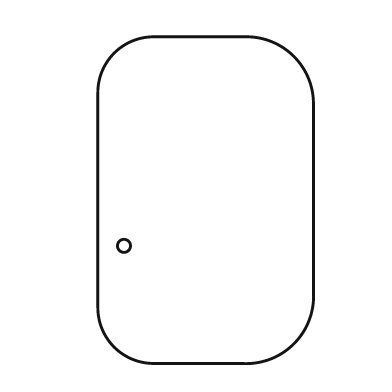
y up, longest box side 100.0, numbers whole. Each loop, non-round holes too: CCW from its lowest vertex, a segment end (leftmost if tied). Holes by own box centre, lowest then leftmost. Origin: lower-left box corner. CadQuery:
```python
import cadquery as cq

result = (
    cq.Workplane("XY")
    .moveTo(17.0, 0.0)
    .lineTo(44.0, 0.0)
    .threePointArc((60.0, 6.0), (66.0, 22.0))
    .lineTo(66.0, 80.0)
    .threePointArc((60.0, 94.0), (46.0, 100.0))
    .lineTo(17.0, 100.0)
    .threePointArc((5.0, 95.0), (0.0, 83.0))
    .lineTo(0.0, 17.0)
    .threePointArc((5.0, 5.0), (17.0, 0.0))
    .close()
    .moveTo(8.0, 36.0)
    .circle(2.0)
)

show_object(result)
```